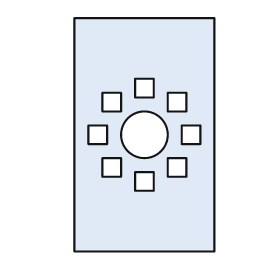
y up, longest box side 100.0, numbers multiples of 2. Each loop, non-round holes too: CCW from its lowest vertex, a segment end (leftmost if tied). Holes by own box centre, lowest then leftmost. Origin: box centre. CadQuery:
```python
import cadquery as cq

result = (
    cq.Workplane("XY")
    .moveTo(-30.0, -50.0)
    .lineTo(30.0, -50.0)
    .lineTo(30.0, 50.0)
    .lineTo(-30.0, 50.0)
    .close()
    .moveTo(-4.0, -24.0)
    .lineTo(4.0, -24.0)
    .lineTo(4.0, -16.0)
    .lineTo(-4.0, -16.0)
    .close()
    .moveTo(-18.0, -18.0)
    .lineTo(-10.0, -18.0)
    .lineTo(-10.0, -10.0)
    .lineTo(-18.0, -10.0)
    .close()
    .moveTo(10.0, -18.0)
    .lineTo(18.0, -18.0)
    .lineTo(18.0, -10.0)
    .lineTo(10.0, -10.0)
    .close()
    .moveTo(-24.0, -4.0)
    .lineTo(-16.0, -4.0)
    .lineTo(-16.0, 4.0)
    .lineTo(-24.0, 4.0)
    .close()
    .moveTo(0.0, 0.0)
    .circle(10.0)
    .moveTo(16.0, -4.0)
    .lineTo(24.0, -4.0)
    .lineTo(24.0, 4.0)
    .lineTo(16.0, 4.0)
    .close()
    .moveTo(-18.0, 10.0)
    .lineTo(-10.0, 10.0)
    .lineTo(-10.0, 18.0)
    .lineTo(-18.0, 18.0)
    .close()
    .moveTo(10.0, 10.0)
    .lineTo(18.0, 10.0)
    .lineTo(18.0, 18.0)
    .lineTo(10.0, 18.0)
    .close()
    .moveTo(-4.0, 16.0)
    .lineTo(4.0, 16.0)
    .lineTo(4.0, 24.0)
    .lineTo(-4.0, 24.0)
    .close()
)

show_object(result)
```